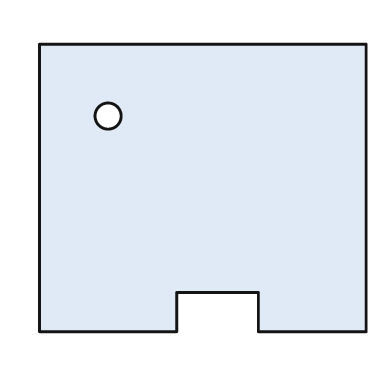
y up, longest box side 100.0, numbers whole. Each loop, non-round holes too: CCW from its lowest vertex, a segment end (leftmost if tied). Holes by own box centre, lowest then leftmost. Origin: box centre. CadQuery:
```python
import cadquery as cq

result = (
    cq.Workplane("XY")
    .moveTo(-50.0, -44.0)
    .lineTo(-8.0, -44.0)
    .lineTo(-8.0, -32.0)
    .lineTo(17.0, -32.0)
    .lineTo(17.0, -44.0)
    .lineTo(50.0, -44.0)
    .lineTo(50.0, 44.0)
    .lineTo(-50.0, 44.0)
    .close()
    .moveTo(-29.0, 22.0)
    .circle(4.0)
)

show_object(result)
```